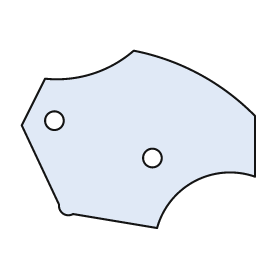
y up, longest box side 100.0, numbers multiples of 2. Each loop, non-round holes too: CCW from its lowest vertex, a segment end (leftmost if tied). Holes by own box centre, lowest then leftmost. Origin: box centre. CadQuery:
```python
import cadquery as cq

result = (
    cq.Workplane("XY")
    .moveTo(8.0, -38.0)
    .threePointArc((24.0, -18.0), (50.0, -16.0))
    .lineTo(50.0, 10.0)
    .threePointArc((26.0, 28.0), (-2.0, 38.0))
    .threePointArc((-20.0, 28.0), (-40.0, 26.0))
    .lineTo(-50.0, 6.0)
    .lineTo(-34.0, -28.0)
    .threePointArc((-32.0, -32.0), (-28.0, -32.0))
    .close()
    .moveTo(6.0, -8.0)
    .circle(4.0)
    .moveTo(-36.0, 8.0)
    .circle(4.0)
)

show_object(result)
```